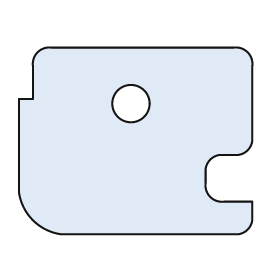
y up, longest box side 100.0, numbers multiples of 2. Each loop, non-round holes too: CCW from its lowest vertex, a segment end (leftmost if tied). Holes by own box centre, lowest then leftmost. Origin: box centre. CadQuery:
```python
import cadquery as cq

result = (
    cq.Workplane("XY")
    .moveTo(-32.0, -40.0)
    .lineTo(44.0, -40.0)
    .threePointArc((48.0, -38.0), (50.0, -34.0))
    .lineTo(50.0, -26.0)
    .lineTo(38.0, -26.0)
    .threePointArc((32.0, -24.0), (30.0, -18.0))
    .lineTo(30.0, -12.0)
    .threePointArc((32.0, -8.0), (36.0, -6.0))
    .lineTo(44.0, -6.0)
    .threePointArc((48.0, -4.0), (50.0, 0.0))
    .lineTo(50.0, 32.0)
    .threePointArc((48.0, 38.0), (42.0, 40.0))
    .lineTo(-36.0, 40.0)
    .threePointArc((-42.0, 38.0), (-44.0, 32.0))
    .lineTo(-44.0, 18.0)
    .lineTo(-50.0, 18.0)
    .lineTo(-50.0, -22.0)
    .threePointArc((-44.0, -34.0), (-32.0, -40.0))
    .close()
    .moveTo(-2.0, 16.0)
    .circle(8.0)
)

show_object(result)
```